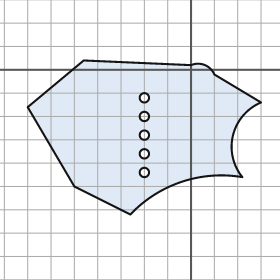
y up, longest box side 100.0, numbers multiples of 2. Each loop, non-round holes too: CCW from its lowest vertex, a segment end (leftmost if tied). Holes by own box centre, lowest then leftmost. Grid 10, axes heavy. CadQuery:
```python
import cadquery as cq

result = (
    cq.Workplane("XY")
    .moveTo(-26.0, -62.0)
    .threePointArc((-4.0, -48.0), (22.0, -46.0))
    .threePointArc((18.0, -28.0), (30.0, -14.0))
    .lineTo(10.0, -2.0)
    .threePointArc((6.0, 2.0), (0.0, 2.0))
    .lineTo(-46.0, 4.0)
    .lineTo(-70.0, -16.0)
    .lineTo(-50.0, -50.0)
    .close()
    .moveTo(-20.0, -44.0)
    .circle(2.0)
    .moveTo(-20.0, -36.0)
    .circle(2.0)
    .moveTo(-20.0, -28.0)
    .circle(2.0)
    .moveTo(-20.0, -20.0)
    .circle(2.0)
    .moveTo(-20.0, -12.0)
    .circle(2.0)
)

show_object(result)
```